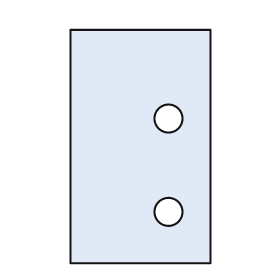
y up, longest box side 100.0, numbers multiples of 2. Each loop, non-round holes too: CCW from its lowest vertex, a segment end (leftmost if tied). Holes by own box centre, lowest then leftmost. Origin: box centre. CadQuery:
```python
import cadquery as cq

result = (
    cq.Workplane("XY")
    .moveTo(-30.0, -50.0)
    .lineTo(30.0, -50.0)
    .lineTo(30.0, 50.0)
    .lineTo(-30.0, 50.0)
    .close()
    .moveTo(12.0, -28.0)
    .circle(6.0)
    .moveTo(12.0, 12.0)
    .circle(6.0)
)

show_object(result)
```